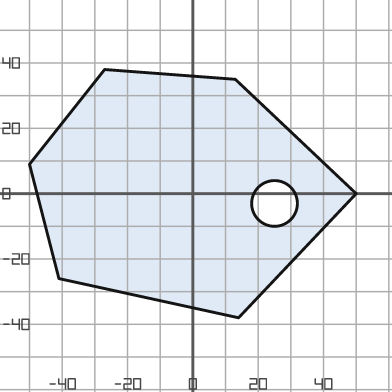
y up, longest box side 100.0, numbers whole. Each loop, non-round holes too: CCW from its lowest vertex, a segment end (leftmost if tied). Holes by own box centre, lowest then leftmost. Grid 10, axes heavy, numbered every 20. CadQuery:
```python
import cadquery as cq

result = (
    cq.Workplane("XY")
    .moveTo(14.0, -38.0)
    .lineTo(50.0, 0.0)
    .lineTo(13.0, 35.0)
    .lineTo(-27.0, 38.0)
    .lineTo(-50.0, 9.0)
    .lineTo(-41.0, -26.0)
    .close()
    .moveTo(25.0, -3.0)
    .circle(7.0)
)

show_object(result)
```